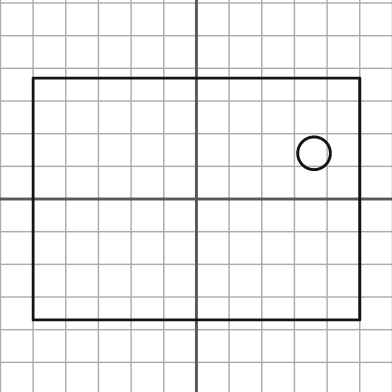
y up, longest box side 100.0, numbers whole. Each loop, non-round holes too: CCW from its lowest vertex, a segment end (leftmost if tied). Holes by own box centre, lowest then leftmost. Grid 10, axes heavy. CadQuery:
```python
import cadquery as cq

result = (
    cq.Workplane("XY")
    .moveTo(-50.0, -37.0)
    .lineTo(50.0, -37.0)
    .lineTo(50.0, 37.0)
    .lineTo(-50.0, 37.0)
    .close()
    .moveTo(36.0, 14.0)
    .circle(5.0)
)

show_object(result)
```